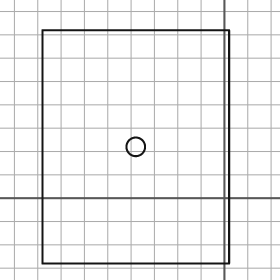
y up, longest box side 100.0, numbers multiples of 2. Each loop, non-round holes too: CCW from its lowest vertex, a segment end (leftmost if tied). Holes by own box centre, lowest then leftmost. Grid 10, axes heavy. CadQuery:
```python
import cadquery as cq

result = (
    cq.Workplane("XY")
    .moveTo(-78.0, -28.0)
    .lineTo(2.0, -28.0)
    .lineTo(2.0, 72.0)
    .lineTo(-78.0, 72.0)
    .close()
    .moveTo(-38.0, 22.0)
    .circle(4.0)
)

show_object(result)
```